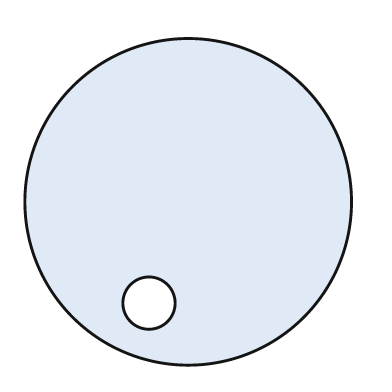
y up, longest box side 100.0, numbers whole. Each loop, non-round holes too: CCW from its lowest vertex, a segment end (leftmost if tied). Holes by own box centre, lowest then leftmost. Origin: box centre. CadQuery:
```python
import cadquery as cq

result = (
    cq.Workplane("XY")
    .moveTo(0.0, 0.0)
    .circle(50.0)
    .moveTo(-12.0, -31.0)
    .circle(8.0)
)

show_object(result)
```